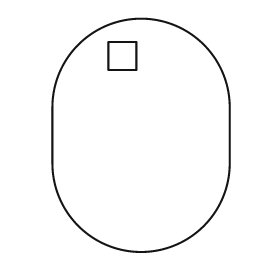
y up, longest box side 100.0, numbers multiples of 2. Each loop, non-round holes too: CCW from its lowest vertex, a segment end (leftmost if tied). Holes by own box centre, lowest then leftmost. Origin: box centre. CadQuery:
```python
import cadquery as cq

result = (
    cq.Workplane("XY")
    .moveTo(-38.0, -12.0)
    .threePointArc((0.0, -50.0), (38.0, -12.0))
    .lineTo(38.0, 12.0)
    .threePointArc((0.0, 50.0), (-38.0, 12.0))
    .close()
    .moveTo(-14.0, 28.0)
    .lineTo(-2.0, 28.0)
    .lineTo(-2.0, 40.0)
    .lineTo(-14.0, 40.0)
    .close()
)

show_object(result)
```